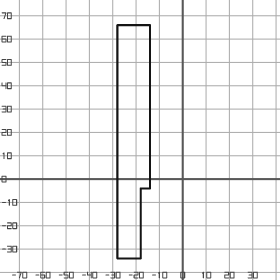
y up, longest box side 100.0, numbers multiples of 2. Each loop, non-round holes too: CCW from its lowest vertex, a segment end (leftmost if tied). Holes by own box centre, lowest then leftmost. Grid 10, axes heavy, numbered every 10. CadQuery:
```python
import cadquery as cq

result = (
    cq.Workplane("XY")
    .moveTo(-28.0, -34.0)
    .lineTo(-18.0, -34.0)
    .lineTo(-18.0, -4.0)
    .lineTo(-14.0, -4.0)
    .lineTo(-14.0, 66.0)
    .lineTo(-28.0, 66.0)
    .close()
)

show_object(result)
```